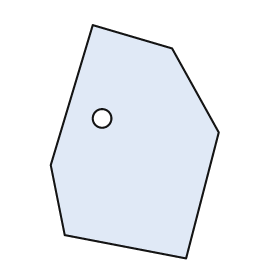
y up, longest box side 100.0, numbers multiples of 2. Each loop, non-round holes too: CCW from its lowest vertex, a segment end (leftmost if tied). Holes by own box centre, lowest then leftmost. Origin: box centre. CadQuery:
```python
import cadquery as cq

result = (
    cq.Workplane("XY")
    .moveTo(22.0, -50.0)
    .lineTo(36.0, 4.0)
    .lineTo(16.0, 40.0)
    .lineTo(-18.0, 50.0)
    .lineTo(-36.0, -10.0)
    .lineTo(-30.0, -40.0)
    .close()
    .moveTo(-14.0, 10.0)
    .circle(4.0)
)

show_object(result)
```